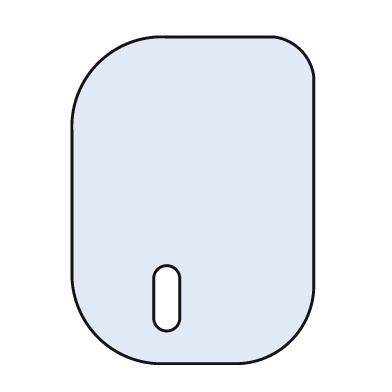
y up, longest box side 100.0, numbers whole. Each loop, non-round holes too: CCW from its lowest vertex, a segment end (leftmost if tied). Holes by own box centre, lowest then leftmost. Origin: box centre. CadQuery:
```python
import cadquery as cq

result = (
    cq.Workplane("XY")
    .moveTo(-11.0, -50.0)
    .lineTo(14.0, -50.0)
    .threePointArc((30.0, -43.0), (37.0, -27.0))
    .lineTo(37.0, 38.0)
    .threePointArc((33.0, 46.0), (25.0, 50.0))
    .lineTo(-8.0, 50.0)
    .threePointArc((-29.0, 42.0), (-37.0, 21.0))
    .lineTo(-37.0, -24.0)
    .threePointArc((-29.0, -42.0), (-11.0, -50.0))
    .close()
    .moveTo(-12.0, -36.0)
    .threePointArc((-8.0, -40.0), (-4.0, -36.0))
    .lineTo(-4.0, -24.0)
    .threePointArc((-8.0, -20.0), (-12.0, -24.0))
    .close()
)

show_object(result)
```